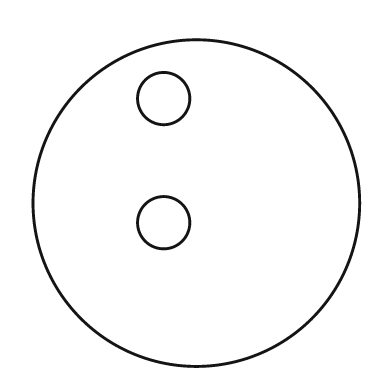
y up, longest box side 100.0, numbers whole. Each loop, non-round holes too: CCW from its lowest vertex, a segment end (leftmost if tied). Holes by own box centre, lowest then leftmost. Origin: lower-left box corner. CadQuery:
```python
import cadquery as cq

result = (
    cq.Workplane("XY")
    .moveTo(50.0, 50.0)
    .circle(50.0)
    .moveTo(40.0, 44.0)
    .circle(8.0)
    .moveTo(40.0, 82.0)
    .circle(8.0)
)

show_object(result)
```